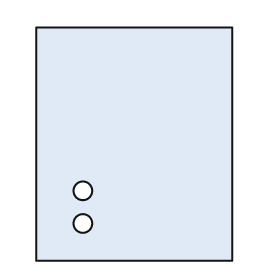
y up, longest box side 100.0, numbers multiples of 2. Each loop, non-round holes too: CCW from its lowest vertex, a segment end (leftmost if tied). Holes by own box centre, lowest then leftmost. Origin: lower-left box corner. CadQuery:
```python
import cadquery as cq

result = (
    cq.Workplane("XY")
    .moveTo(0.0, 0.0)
    .lineTo(84.0, 0.0)
    .lineTo(84.0, 100.0)
    .lineTo(0.0, 100.0)
    .close()
    .moveTo(20.0, 16.0)
    .circle(4.0)
    .moveTo(20.0, 30.0)
    .circle(4.0)
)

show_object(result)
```